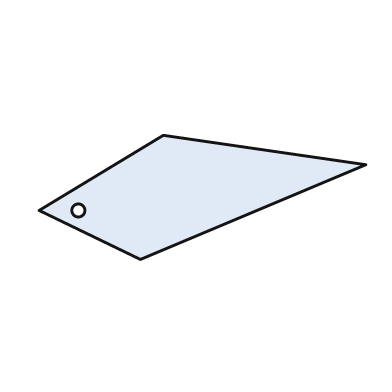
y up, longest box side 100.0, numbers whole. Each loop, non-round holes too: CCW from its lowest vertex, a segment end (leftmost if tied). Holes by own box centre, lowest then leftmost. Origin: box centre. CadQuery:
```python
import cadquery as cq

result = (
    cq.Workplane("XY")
    .moveTo(-19.0, -19.0)
    .lineTo(50.0, 10.0)
    .lineTo(-12.0, 19.0)
    .lineTo(-50.0, -4.0)
    .close()
    .moveTo(-38.0, -4.0)
    .circle(2.0)
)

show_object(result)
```